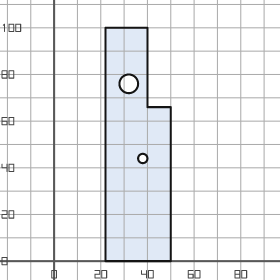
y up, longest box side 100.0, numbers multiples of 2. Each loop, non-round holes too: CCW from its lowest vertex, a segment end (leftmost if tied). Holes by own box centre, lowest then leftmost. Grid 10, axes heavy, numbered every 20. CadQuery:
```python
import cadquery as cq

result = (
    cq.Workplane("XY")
    .moveTo(22.0, 0.0)
    .lineTo(50.0, 0.0)
    .lineTo(50.0, 66.0)
    .lineTo(40.0, 66.0)
    .lineTo(40.0, 100.0)
    .lineTo(22.0, 100.0)
    .close()
    .moveTo(38.0, 44.0)
    .circle(2.0)
    .moveTo(32.0, 76.0)
    .circle(4.0)
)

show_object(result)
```